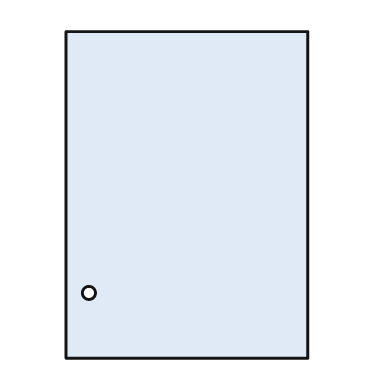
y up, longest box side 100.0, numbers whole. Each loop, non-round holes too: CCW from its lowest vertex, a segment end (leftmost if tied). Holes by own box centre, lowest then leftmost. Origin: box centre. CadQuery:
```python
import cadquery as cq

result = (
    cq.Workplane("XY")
    .moveTo(-37.0, -50.0)
    .lineTo(37.0, -50.0)
    .lineTo(37.0, 50.0)
    .lineTo(-37.0, 50.0)
    .close()
    .moveTo(-30.0, -30.0)
    .circle(2.0)
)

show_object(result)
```